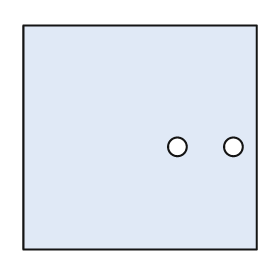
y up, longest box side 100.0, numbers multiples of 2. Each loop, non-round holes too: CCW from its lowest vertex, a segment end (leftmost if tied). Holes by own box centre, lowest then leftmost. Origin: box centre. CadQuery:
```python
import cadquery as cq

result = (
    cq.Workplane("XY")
    .moveTo(-50.0, -48.0)
    .lineTo(50.0, -48.0)
    .lineTo(50.0, 48.0)
    .lineTo(-50.0, 48.0)
    .close()
    .moveTo(16.0, -4.0)
    .circle(4.0)
    .moveTo(40.0, -4.0)
    .circle(4.0)
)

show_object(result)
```